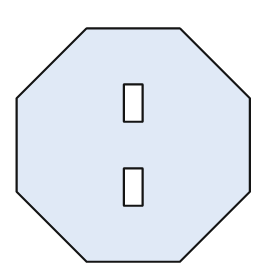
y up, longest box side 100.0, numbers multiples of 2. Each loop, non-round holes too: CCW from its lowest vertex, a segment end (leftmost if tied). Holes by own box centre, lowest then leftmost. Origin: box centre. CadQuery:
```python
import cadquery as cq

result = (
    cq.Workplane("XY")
    .moveTo(-20.0, -50.0)
    .lineTo(20.0, -50.0)
    .lineTo(50.0, -20.0)
    .lineTo(50.0, 20.0)
    .lineTo(20.0, 50.0)
    .lineTo(-20.0, 50.0)
    .lineTo(-50.0, 20.0)
    .lineTo(-50.0, -20.0)
    .close()
    .moveTo(-4.0, -26.0)
    .lineTo(4.0, -26.0)
    .lineTo(4.0, -10.0)
    .lineTo(-4.0, -10.0)
    .close()
    .moveTo(-4.0, 10.0)
    .lineTo(4.0, 10.0)
    .lineTo(4.0, 26.0)
    .lineTo(-4.0, 26.0)
    .close()
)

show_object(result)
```